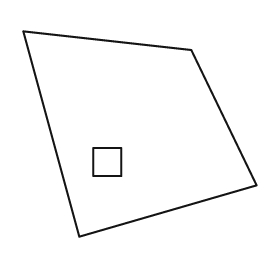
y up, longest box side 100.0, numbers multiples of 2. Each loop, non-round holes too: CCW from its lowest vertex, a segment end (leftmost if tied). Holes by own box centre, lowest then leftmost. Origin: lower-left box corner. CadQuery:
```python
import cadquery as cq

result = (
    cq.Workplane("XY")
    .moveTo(24.0, 0.0)
    .lineTo(100.0, 22.0)
    .lineTo(72.0, 80.0)
    .lineTo(0.0, 88.0)
    .close()
    .moveTo(30.0, 26.0)
    .lineTo(42.0, 26.0)
    .lineTo(42.0, 38.0)
    .lineTo(30.0, 38.0)
    .close()
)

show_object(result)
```